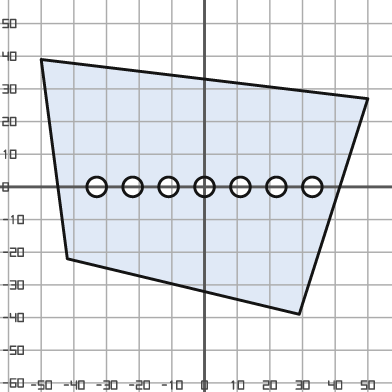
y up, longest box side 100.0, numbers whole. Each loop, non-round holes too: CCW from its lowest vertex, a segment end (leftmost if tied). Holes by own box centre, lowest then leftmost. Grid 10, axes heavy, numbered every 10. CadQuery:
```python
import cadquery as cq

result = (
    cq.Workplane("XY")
    .moveTo(29.0, -39.0)
    .lineTo(50.0, 27.0)
    .lineTo(-50.0, 39.0)
    .lineTo(-42.0, -22.0)
    .close()
    .moveTo(-33.0, 0.0)
    .circle(3.0)
    .moveTo(-22.0, 0.0)
    .circle(3.0)
    .moveTo(-11.0, 0.0)
    .circle(3.0)
    .moveTo(0.0, 0.0)
    .circle(3.0)
    .moveTo(11.0, 0.0)
    .circle(3.0)
    .moveTo(22.0, 0.0)
    .circle(3.0)
    .moveTo(33.0, 0.0)
    .circle(3.0)
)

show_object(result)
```